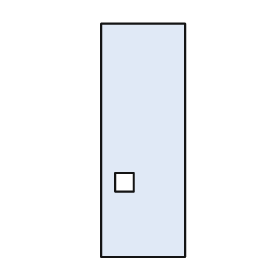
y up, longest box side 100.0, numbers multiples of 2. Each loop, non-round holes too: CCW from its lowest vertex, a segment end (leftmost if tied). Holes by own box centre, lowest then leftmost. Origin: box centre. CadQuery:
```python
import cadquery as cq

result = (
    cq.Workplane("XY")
    .moveTo(-18.0, -50.0)
    .lineTo(18.0, -50.0)
    .lineTo(18.0, 50.0)
    .lineTo(-18.0, 50.0)
    .close()
    .moveTo(-12.0, -22.0)
    .lineTo(-4.0, -22.0)
    .lineTo(-4.0, -14.0)
    .lineTo(-12.0, -14.0)
    .close()
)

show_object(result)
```